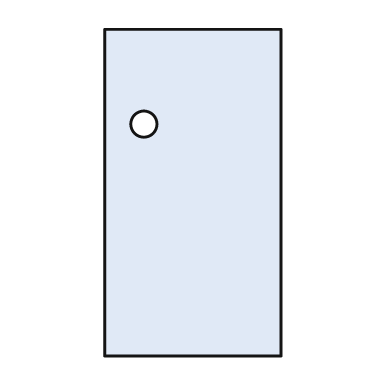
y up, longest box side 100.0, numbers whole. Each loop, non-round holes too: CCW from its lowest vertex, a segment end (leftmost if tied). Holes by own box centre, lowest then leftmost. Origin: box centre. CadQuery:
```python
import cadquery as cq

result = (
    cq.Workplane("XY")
    .moveTo(-27.0, -50.0)
    .lineTo(27.0, -50.0)
    .lineTo(27.0, 50.0)
    .lineTo(-27.0, 50.0)
    .close()
    .moveTo(-15.0, 21.0)
    .circle(4.0)
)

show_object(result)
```